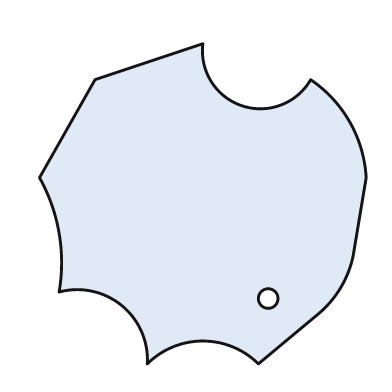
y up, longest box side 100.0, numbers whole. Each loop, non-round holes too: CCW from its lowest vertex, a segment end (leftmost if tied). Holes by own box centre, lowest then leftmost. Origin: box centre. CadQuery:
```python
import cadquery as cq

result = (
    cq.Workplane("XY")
    .moveTo(-17.0, -49.0)
    .threePointArc((0.0, -42.0), (17.0, -49.0))
    .lineTo(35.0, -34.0)
    .threePointArc((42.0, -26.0), (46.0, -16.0))
    .lineTo(50.0, 8.0)
    .threePointArc((45.0, 25.0), (33.0, 38.0))
    .threePointArc((12.0, 30.0), (0.0, 49.0))
    .lineTo(-33.0, 38.0)
    .lineTo(-50.0, 8.0)
    .threePointArc((-44.0, -9.0), (-44.0, -27.0))
    .threePointArc((-25.0, -31.0), (-17.0, -49.0))
    .close()
    .moveTo(20.0, -29.0)
    .circle(3.0)
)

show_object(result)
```